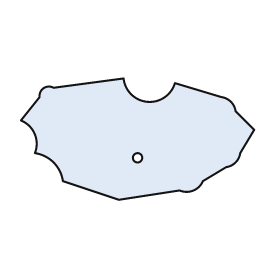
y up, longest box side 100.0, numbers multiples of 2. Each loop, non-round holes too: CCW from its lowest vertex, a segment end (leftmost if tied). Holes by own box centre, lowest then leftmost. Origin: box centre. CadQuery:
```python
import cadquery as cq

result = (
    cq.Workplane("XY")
    .moveTo(-8.0, -26.0)
    .lineTo(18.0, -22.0)
    .threePointArc((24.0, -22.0), (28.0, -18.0))
    .lineTo(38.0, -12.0)
    .threePointArc((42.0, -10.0), (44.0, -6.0))
    .lineTo(50.0, 4.0)
    .lineTo(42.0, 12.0)
    .threePointArc((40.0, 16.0), (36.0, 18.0))
    .lineTo(16.0, 24.0)
    .threePointArc((4.0, 16.0), (-6.0, 26.0))
    .lineTo(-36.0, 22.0)
    .threePointArc((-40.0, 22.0), (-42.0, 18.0))
    .lineTo(-50.0, 8.0)
    .threePointArc((-44.0, 2.0), (-44.0, -6.0))
    .threePointArc((-36.0, -10.0), (-32.0, -18.0))
    .close()
    .moveTo(0.0, -8.0)
    .circle(2.0)
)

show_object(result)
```